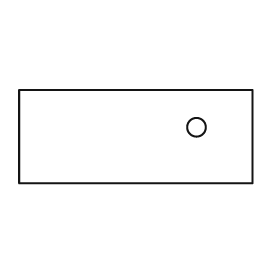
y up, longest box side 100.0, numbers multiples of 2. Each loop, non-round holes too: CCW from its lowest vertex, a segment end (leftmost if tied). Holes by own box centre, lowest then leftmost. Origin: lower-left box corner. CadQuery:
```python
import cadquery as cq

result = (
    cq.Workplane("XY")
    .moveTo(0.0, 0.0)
    .lineTo(100.0, 0.0)
    .lineTo(100.0, 40.0)
    .lineTo(0.0, 40.0)
    .close()
    .moveTo(76.0, 24.0)
    .circle(4.0)
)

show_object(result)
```